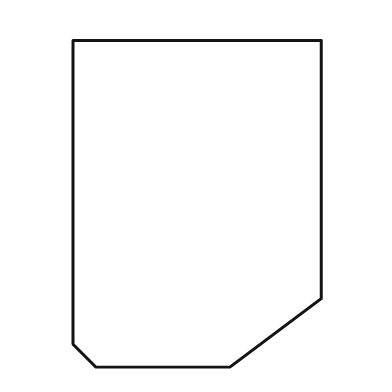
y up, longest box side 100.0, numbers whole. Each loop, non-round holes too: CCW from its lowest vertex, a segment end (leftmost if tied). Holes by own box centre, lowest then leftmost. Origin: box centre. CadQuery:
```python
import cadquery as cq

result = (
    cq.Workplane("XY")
    .moveTo(-31.0, -50.0)
    .lineTo(10.0, -50.0)
    .lineTo(38.0, -29.0)
    .lineTo(38.0, 50.0)
    .lineTo(-38.0, 50.0)
    .lineTo(-38.0, -43.0)
    .close()
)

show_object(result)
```